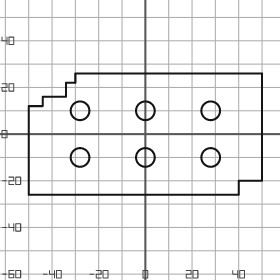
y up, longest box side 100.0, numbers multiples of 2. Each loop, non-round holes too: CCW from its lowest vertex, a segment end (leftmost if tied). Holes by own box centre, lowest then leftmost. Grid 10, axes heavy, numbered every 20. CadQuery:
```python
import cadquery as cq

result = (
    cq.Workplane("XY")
    .moveTo(-50.0, -26.0)
    .lineTo(40.0, -26.0)
    .lineTo(40.0, -20.0)
    .lineTo(50.0, -20.0)
    .lineTo(50.0, 26.0)
    .lineTo(-30.0, 26.0)
    .lineTo(-30.0, 22.0)
    .lineTo(-34.0, 22.0)
    .lineTo(-34.0, 16.0)
    .lineTo(-44.0, 16.0)
    .lineTo(-44.0, 12.0)
    .lineTo(-50.0, 12.0)
    .close()
    .moveTo(-28.0, -10.0)
    .circle(4.0)
    .moveTo(0.0, -10.0)
    .circle(4.0)
    .moveTo(28.0, -10.0)
    .circle(4.0)
    .moveTo(-28.0, 10.0)
    .circle(4.0)
    .moveTo(0.0, 10.0)
    .circle(4.0)
    .moveTo(28.0, 10.0)
    .circle(4.0)
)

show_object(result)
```